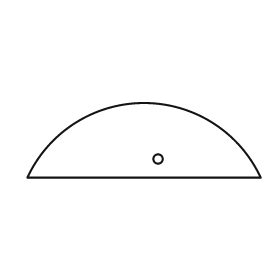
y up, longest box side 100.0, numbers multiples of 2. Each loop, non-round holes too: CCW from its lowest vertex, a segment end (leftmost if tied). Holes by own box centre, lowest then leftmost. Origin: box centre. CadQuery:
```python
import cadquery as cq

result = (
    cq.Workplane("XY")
    .moveTo(-50.0, -16.0)
    .lineTo(50.0, -16.0)
    .threePointArc((0.0, 16.0), (-50.0, -16.0))
    .close()
    .moveTo(6.0, -8.0)
    .circle(2.0)
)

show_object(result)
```